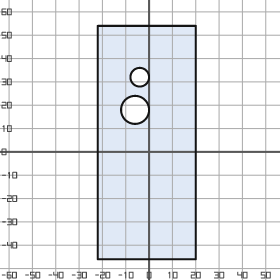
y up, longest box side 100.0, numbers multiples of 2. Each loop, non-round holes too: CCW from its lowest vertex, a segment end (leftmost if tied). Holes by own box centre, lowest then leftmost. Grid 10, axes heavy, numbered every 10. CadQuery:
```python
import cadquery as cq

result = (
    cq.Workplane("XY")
    .moveTo(-22.0, -46.0)
    .lineTo(20.0, -46.0)
    .lineTo(20.0, 54.0)
    .lineTo(-22.0, 54.0)
    .close()
    .moveTo(-6.0, 18.0)
    .circle(6.0)
    .moveTo(-4.0, 32.0)
    .circle(4.0)
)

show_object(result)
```